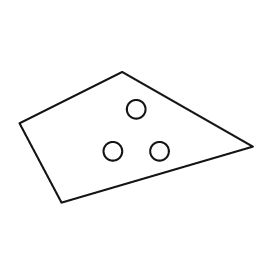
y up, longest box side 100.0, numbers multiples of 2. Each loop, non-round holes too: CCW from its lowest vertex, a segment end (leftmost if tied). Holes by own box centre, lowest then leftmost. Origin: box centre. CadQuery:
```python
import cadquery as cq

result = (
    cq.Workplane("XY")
    .moveTo(-32.0, -28.0)
    .lineTo(50.0, -4.0)
    .lineTo(-6.0, 28.0)
    .lineTo(-50.0, 6.0)
    .close()
    .moveTo(-10.0, -6.0)
    .circle(4.0)
    .moveTo(10.0, -6.0)
    .circle(4.0)
    .moveTo(0.0, 12.0)
    .circle(4.0)
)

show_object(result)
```